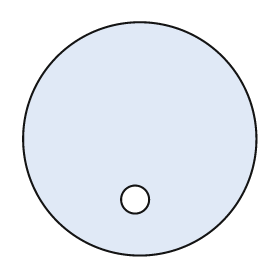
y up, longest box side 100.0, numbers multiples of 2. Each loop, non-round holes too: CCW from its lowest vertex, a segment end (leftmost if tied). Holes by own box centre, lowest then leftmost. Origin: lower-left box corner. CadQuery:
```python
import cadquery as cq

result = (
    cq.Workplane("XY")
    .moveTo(50.0, 50.0)
    .circle(50.0)
    .moveTo(48.0, 24.0)
    .circle(6.0)
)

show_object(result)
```